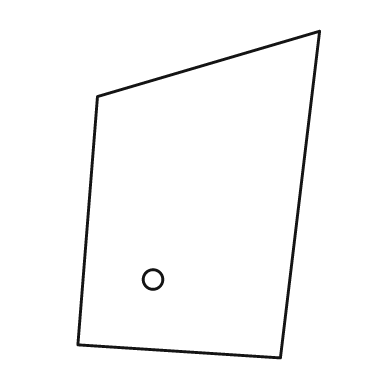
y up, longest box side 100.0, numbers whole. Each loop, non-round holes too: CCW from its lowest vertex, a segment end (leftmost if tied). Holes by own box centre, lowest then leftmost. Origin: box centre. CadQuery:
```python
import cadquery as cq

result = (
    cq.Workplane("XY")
    .moveTo(25.0, -50.0)
    .lineTo(37.0, 50.0)
    .lineTo(-31.0, 30.0)
    .lineTo(-37.0, -46.0)
    .close()
    .moveTo(-14.0, -26.0)
    .circle(3.0)
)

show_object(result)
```